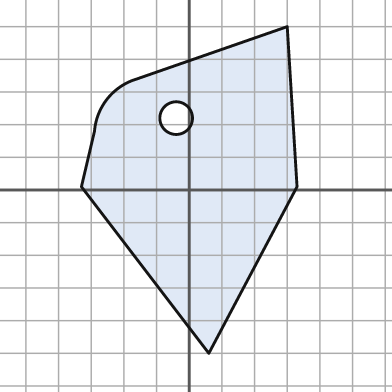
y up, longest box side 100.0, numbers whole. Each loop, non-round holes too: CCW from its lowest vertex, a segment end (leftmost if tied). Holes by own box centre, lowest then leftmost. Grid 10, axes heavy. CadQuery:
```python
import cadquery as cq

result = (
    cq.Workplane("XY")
    .moveTo(6.0, -50.0)
    .lineTo(33.0, 1.0)
    .lineTo(30.0, 50.0)
    .lineTo(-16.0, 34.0)
    .threePointArc((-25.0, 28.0), (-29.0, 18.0))
    .lineTo(-33.0, 1.0)
    .close()
    .moveTo(-4.0, 22.0)
    .circle(5.0)
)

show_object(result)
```